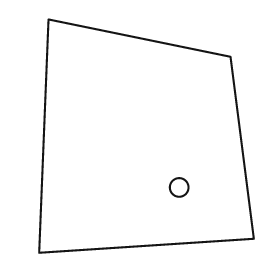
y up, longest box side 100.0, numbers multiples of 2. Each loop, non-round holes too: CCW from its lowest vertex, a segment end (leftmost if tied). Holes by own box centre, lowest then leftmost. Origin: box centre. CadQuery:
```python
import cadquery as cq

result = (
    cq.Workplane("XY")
    .moveTo(-46.0, -50.0)
    .lineTo(46.0, -44.0)
    .lineTo(36.0, 34.0)
    .lineTo(-42.0, 50.0)
    .close()
    .moveTo(14.0, -22.0)
    .circle(4.0)
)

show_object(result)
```